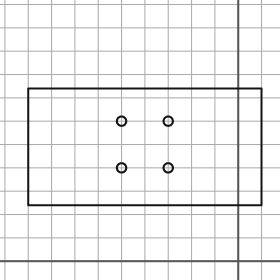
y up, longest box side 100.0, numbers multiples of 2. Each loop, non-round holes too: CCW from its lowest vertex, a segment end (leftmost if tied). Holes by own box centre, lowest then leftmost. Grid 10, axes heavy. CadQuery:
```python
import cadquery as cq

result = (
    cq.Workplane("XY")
    .moveTo(-90.0, 24.0)
    .lineTo(10.0, 24.0)
    .lineTo(10.0, 74.0)
    .lineTo(-90.0, 74.0)
    .close()
    .moveTo(-50.0, 40.0)
    .circle(2.0)
    .moveTo(-30.0, 40.0)
    .circle(2.0)
    .moveTo(-50.0, 60.0)
    .circle(2.0)
    .moveTo(-30.0, 60.0)
    .circle(2.0)
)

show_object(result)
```